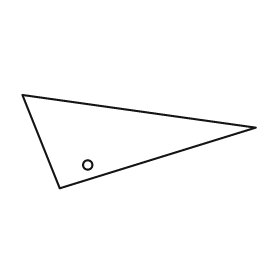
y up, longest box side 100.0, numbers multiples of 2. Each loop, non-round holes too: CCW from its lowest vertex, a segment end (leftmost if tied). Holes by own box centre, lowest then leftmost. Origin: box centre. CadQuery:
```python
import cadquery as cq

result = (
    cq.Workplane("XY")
    .moveTo(-34.0, -20.0)
    .lineTo(50.0, 6.0)
    .lineTo(-50.0, 20.0)
    .close()
    .moveTo(-22.0, -10.0)
    .circle(2.0)
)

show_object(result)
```